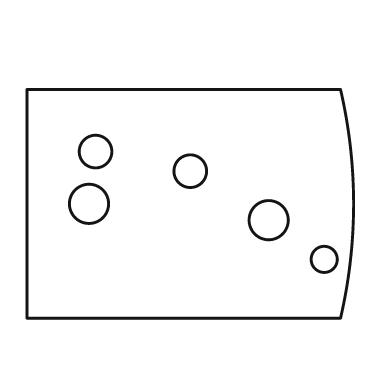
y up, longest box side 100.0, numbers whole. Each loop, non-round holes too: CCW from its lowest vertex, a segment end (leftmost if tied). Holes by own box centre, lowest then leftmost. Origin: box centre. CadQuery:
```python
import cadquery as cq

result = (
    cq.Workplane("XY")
    .moveTo(-50.0, -35.0)
    .lineTo(46.0, -35.0)
    .threePointArc((50.0, 0.0), (46.0, 35.0))
    .lineTo(-50.0, 35.0)
    .close()
    .moveTo(41.0, -17.0)
    .circle(4.0)
    .moveTo(24.0, -5.0)
    .circle(6.0)
    .moveTo(-31.0, 0.0)
    .circle(6.0)
    .moveTo(0.0, 10.0)
    .circle(5.0)
    .moveTo(-29.0, 16.0)
    .circle(5.0)
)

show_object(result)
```